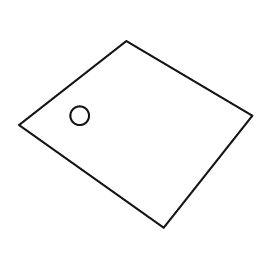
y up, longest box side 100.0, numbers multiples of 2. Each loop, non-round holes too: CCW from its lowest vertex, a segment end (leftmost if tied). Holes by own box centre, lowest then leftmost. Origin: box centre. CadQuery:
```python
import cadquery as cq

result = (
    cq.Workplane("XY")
    .moveTo(12.0, -40.0)
    .lineTo(50.0, 8.0)
    .lineTo(-4.0, 40.0)
    .lineTo(-50.0, 4.0)
    .close()
    .moveTo(-24.0, 8.0)
    .circle(4.0)
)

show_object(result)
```